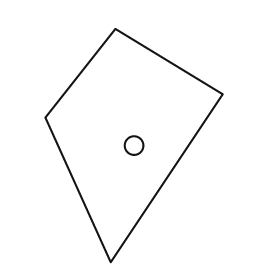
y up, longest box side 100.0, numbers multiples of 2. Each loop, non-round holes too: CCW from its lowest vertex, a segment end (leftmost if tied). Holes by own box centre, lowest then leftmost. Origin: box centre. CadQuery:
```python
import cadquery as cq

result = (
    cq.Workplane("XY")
    .moveTo(-10.0, -50.0)
    .lineTo(38.0, 22.0)
    .lineTo(-8.0, 50.0)
    .lineTo(-38.0, 12.0)
    .close()
    .moveTo(0.0, 0.0)
    .circle(4.0)
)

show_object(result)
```